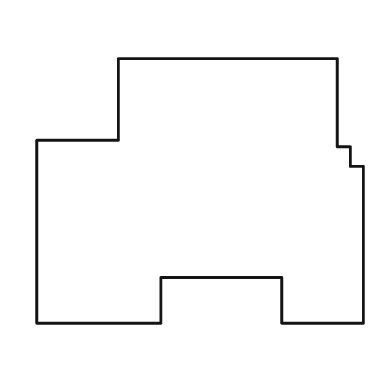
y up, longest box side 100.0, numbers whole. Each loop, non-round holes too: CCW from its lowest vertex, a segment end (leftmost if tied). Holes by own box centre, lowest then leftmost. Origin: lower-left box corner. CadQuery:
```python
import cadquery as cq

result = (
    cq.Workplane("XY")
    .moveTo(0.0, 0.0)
    .lineTo(38.0, 0.0)
    .lineTo(38.0, 14.0)
    .lineTo(75.0, 14.0)
    .lineTo(75.0, 0.0)
    .lineTo(100.0, 0.0)
    .lineTo(100.0, 48.0)
    .lineTo(96.0, 48.0)
    .lineTo(96.0, 54.0)
    .lineTo(92.0, 54.0)
    .lineTo(92.0, 81.0)
    .lineTo(25.0, 81.0)
    .lineTo(25.0, 56.0)
    .lineTo(0.0, 56.0)
    .close()
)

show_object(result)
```